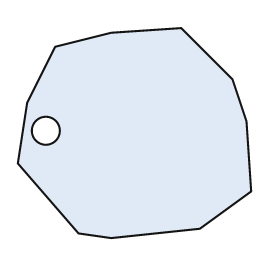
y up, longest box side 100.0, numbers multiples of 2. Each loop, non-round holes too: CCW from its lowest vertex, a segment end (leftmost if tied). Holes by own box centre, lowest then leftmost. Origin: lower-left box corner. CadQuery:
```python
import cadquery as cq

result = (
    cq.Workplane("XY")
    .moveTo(40.0, 0.0)
    .lineTo(78.0, 4.0)
    .lineTo(100.0, 20.0)
    .lineTo(98.0, 50.0)
    .lineTo(92.0, 68.0)
    .lineTo(70.0, 90.0)
    .lineTo(40.0, 88.0)
    .lineTo(16.0, 82.0)
    .lineTo(4.0, 58.0)
    .lineTo(0.0, 32.0)
    .lineTo(26.0, 2.0)
    .close()
    .moveTo(12.0, 46.0)
    .circle(6.0)
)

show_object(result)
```